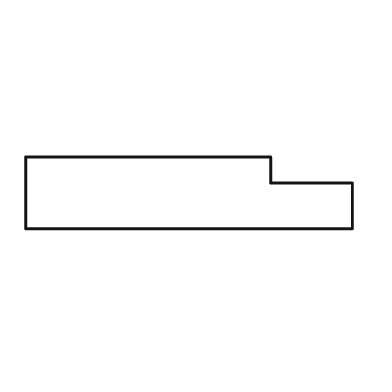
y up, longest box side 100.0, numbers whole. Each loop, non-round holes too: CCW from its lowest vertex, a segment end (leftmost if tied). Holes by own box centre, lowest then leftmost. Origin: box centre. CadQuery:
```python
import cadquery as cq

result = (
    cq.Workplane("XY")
    .moveTo(-50.0, -11.0)
    .lineTo(50.0, -11.0)
    .lineTo(50.0, 3.0)
    .lineTo(25.0, 3.0)
    .lineTo(25.0, 11.0)
    .lineTo(-50.0, 11.0)
    .close()
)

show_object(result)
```